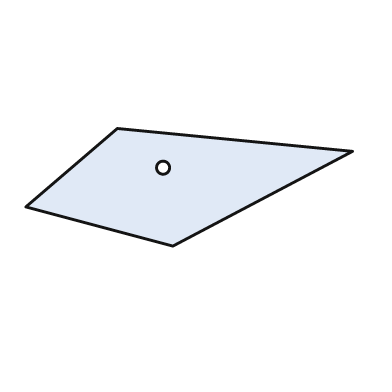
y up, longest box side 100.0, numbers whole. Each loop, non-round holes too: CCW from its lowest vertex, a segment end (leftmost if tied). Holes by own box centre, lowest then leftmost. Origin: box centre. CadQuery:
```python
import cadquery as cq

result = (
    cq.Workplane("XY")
    .moveTo(-5.0, -18.0)
    .lineTo(50.0, 11.0)
    .lineTo(-22.0, 18.0)
    .lineTo(-50.0, -6.0)
    .close()
    .moveTo(-8.0, 6.0)
    .circle(2.0)
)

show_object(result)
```